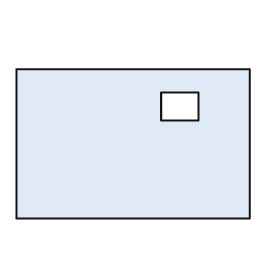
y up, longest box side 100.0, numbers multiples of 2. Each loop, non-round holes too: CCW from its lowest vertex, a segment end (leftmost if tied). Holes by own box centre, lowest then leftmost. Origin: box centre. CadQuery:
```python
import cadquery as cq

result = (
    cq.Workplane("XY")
    .moveTo(-50.0, -32.0)
    .lineTo(50.0, -32.0)
    .lineTo(50.0, 32.0)
    .lineTo(-50.0, 32.0)
    .close()
    .moveTo(12.0, 10.0)
    .lineTo(28.0, 10.0)
    .lineTo(28.0, 22.0)
    .lineTo(12.0, 22.0)
    .close()
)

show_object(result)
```